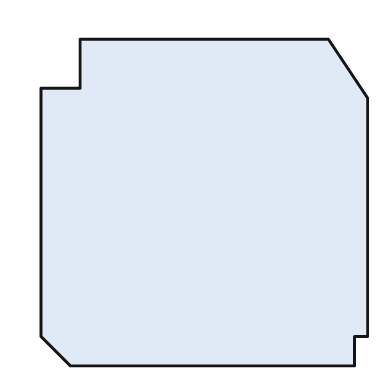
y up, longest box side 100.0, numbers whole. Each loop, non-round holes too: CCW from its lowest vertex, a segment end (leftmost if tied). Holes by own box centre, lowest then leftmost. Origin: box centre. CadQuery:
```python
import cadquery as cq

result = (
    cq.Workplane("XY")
    .moveTo(-41.0, -50.0)
    .lineTo(46.0, -50.0)
    .lineTo(46.0, -41.0)
    .lineTo(50.0, -41.0)
    .lineTo(50.0, 32.0)
    .lineTo(38.0, 50.0)
    .lineTo(-38.0, 50.0)
    .lineTo(-38.0, 35.0)
    .lineTo(-50.0, 35.0)
    .lineTo(-50.0, -41.0)
    .close()
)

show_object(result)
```